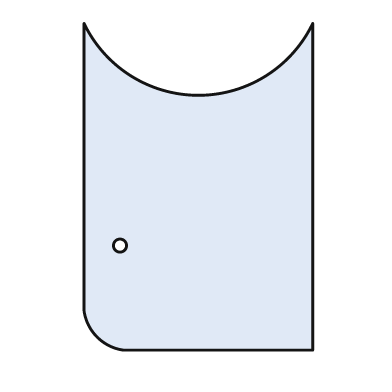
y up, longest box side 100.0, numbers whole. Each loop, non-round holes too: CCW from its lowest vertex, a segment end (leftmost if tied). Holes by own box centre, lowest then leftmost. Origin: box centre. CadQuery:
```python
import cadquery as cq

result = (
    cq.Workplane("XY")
    .moveTo(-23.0, -50.0)
    .lineTo(35.0, -50.0)
    .lineTo(35.0, 50.0)
    .threePointArc((0.0, 28.0), (-35.0, 50.0))
    .lineTo(-35.0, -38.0)
    .threePointArc((-31.0, -46.0), (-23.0, -50.0))
    .close()
    .moveTo(-24.0, -18.0)
    .circle(2.0)
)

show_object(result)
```